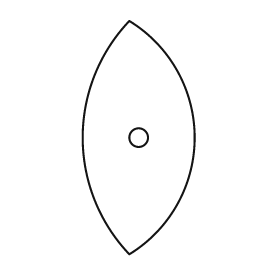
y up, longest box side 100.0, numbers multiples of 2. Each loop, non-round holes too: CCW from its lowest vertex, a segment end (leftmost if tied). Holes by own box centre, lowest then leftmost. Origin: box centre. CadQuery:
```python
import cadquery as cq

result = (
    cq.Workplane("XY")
    .moveTo(-4.0, -50.0)
    .threePointArc((24.0, 0.0), (-4.0, 50.0))
    .threePointArc((-24.0, 0.0), (-4.0, -50.0))
    .close()
    .moveTo(0.0, 0.0)
    .circle(4.0)
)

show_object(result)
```